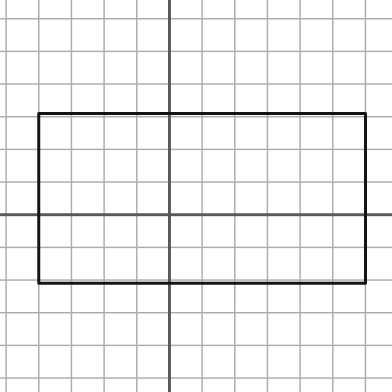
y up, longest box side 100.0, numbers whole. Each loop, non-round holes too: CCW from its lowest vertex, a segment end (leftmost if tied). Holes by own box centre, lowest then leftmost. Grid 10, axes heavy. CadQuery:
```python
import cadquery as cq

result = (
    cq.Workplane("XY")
    .moveTo(-40.0, -21.0)
    .lineTo(60.0, -21.0)
    .lineTo(60.0, 31.0)
    .lineTo(-40.0, 31.0)
    .close()
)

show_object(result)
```